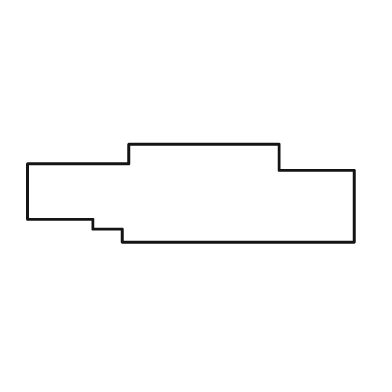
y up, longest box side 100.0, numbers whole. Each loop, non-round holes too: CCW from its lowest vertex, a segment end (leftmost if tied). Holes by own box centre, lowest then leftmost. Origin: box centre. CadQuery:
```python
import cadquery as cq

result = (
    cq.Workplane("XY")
    .moveTo(-21.0, -15.0)
    .lineTo(50.0, -15.0)
    .lineTo(50.0, 7.0)
    .lineTo(27.0, 7.0)
    .lineTo(27.0, 15.0)
    .lineTo(-19.0, 15.0)
    .lineTo(-19.0, 9.0)
    .lineTo(-50.0, 9.0)
    .lineTo(-50.0, -8.0)
    .lineTo(-30.0, -8.0)
    .lineTo(-30.0, -11.0)
    .lineTo(-21.0, -11.0)
    .close()
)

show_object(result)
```